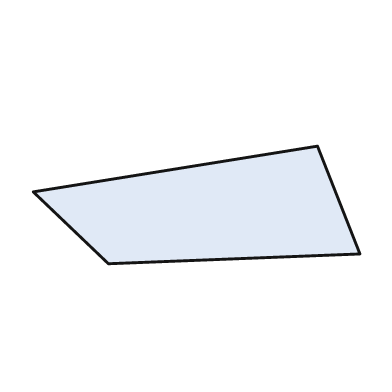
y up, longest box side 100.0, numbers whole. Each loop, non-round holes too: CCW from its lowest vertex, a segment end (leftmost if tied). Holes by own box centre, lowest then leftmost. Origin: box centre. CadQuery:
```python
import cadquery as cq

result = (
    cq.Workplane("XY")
    .moveTo(-27.0, -18.0)
    .lineTo(50.0, -15.0)
    .lineTo(37.0, 18.0)
    .lineTo(-50.0, 4.0)
    .close()
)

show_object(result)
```